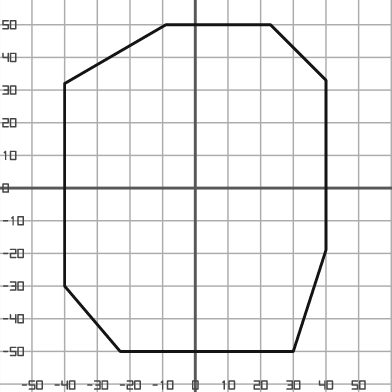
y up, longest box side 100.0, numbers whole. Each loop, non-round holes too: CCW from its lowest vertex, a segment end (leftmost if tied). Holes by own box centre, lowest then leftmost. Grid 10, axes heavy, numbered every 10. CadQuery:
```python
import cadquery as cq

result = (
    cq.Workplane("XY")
    .moveTo(-23.0, -50.0)
    .lineTo(30.0, -50.0)
    .lineTo(40.0, -19.0)
    .lineTo(40.0, 33.0)
    .lineTo(23.0, 50.0)
    .lineTo(-9.0, 50.0)
    .lineTo(-40.0, 32.0)
    .lineTo(-40.0, -30.0)
    .close()
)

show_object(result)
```